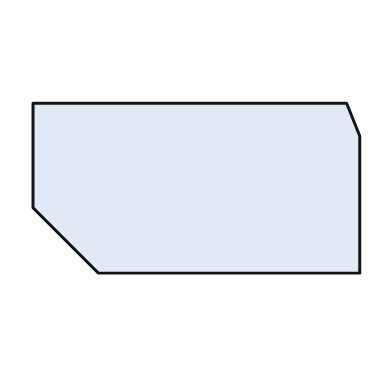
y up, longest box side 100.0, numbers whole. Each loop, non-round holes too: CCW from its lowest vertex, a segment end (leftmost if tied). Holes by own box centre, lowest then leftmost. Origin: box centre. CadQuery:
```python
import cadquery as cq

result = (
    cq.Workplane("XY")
    .moveTo(-30.0, -26.0)
    .lineTo(50.0, -26.0)
    .lineTo(50.0, 16.0)
    .lineTo(46.0, 26.0)
    .lineTo(-50.0, 26.0)
    .lineTo(-50.0, -6.0)
    .close()
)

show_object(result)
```